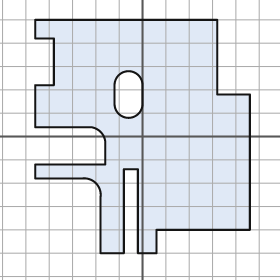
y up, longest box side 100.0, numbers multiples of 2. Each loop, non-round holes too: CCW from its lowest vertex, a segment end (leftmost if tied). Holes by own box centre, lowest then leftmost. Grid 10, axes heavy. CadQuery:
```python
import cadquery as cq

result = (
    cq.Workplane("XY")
    .moveTo(-18.0, -50.0)
    .lineTo(-8.0, -50.0)
    .lineTo(-8.0, -14.0)
    .lineTo(-2.0, -14.0)
    .lineTo(-2.0, -50.0)
    .lineTo(6.0, -50.0)
    .lineTo(6.0, -40.0)
    .lineTo(46.0, -40.0)
    .lineTo(46.0, 18.0)
    .lineTo(32.0, 18.0)
    .lineTo(32.0, 50.0)
    .lineTo(-46.0, 50.0)
    .lineTo(-46.0, 42.0)
    .lineTo(-38.0, 42.0)
    .lineTo(-38.0, 22.0)
    .lineTo(-46.0, 22.0)
    .lineTo(-46.0, 4.0)
    .lineTo(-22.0, 4.0)
    .threePointArc((-18.0, 2.0), (-16.0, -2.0))
    .lineTo(-16.0, -12.0)
    .lineTo(-46.0, -12.0)
    .lineTo(-46.0, -18.0)
    .lineTo(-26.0, -18.0)
    .threePointArc((-20.0, -20.0), (-18.0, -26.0))
    .close()
    .moveTo(-12.0, 14.0)
    .threePointArc((-6.0, 8.0), (0.0, 14.0))
    .lineTo(0.0, 22.0)
    .threePointArc((-6.0, 28.0), (-12.0, 22.0))
    .close()
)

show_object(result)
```